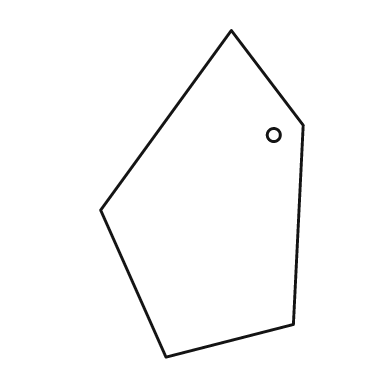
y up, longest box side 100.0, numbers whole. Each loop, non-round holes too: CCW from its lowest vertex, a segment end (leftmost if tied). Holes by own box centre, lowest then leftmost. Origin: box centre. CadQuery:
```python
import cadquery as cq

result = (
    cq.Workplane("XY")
    .moveTo(-11.0, -50.0)
    .lineTo(28.0, -40.0)
    .lineTo(31.0, 21.0)
    .lineTo(9.0, 50.0)
    .lineTo(-31.0, -5.0)
    .close()
    .moveTo(22.0, 18.0)
    .circle(2.0)
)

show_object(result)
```